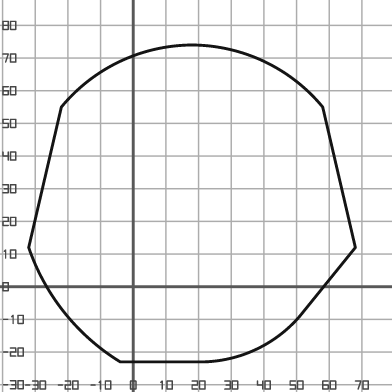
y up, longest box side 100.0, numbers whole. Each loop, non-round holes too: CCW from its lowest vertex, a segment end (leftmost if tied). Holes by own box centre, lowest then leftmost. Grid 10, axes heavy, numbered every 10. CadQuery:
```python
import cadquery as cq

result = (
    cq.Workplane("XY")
    .moveTo(-4.0, -23.0)
    .lineTo(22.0, -23.0)
    .threePointArc((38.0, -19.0), (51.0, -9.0))
    .lineTo(68.0, 12.0)
    .lineTo(58.0, 55.0)
    .threePointArc((40.0, 69.0), (18.0, 74.0))
    .threePointArc((-4.0, 69.0), (-22.0, 55.0))
    .lineTo(-32.0, 12.0)
    .threePointArc((-21.0, -8.0), (-4.0, -23.0))
    .close()
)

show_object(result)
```